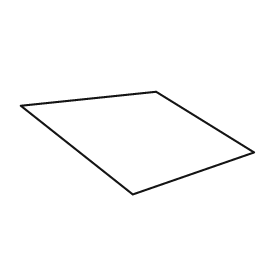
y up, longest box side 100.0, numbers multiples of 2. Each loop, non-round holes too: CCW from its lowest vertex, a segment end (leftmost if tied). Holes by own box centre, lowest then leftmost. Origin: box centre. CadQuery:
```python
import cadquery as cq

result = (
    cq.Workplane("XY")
    .moveTo(-2.0, -22.0)
    .lineTo(50.0, -4.0)
    .lineTo(8.0, 22.0)
    .lineTo(-50.0, 16.0)
    .close()
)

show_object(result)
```